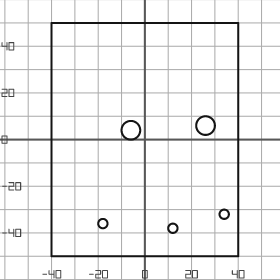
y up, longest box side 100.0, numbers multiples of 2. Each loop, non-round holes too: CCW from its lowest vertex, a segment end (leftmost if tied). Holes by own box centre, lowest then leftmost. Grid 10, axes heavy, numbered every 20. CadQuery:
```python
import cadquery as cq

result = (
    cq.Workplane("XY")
    .moveTo(-40.0, -50.0)
    .lineTo(40.0, -50.0)
    .lineTo(40.0, 50.0)
    .lineTo(-40.0, 50.0)
    .close()
    .moveTo(12.0, -38.0)
    .circle(2.0)
    .moveTo(-18.0, -36.0)
    .circle(2.0)
    .moveTo(34.0, -32.0)
    .circle(2.0)
    .moveTo(-6.0, 4.0)
    .circle(4.0)
    .moveTo(26.0, 6.0)
    .circle(4.0)
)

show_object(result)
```